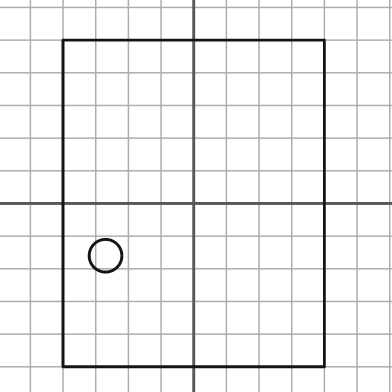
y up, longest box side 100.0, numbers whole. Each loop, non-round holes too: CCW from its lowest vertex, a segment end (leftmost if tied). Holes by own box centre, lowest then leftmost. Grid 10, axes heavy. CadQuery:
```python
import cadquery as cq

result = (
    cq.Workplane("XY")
    .moveTo(-40.0, -50.0)
    .lineTo(40.0, -50.0)
    .lineTo(40.0, 50.0)
    .lineTo(-40.0, 50.0)
    .close()
    .moveTo(-27.0, -16.0)
    .circle(5.0)
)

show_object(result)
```